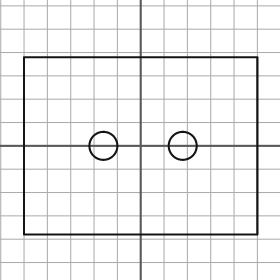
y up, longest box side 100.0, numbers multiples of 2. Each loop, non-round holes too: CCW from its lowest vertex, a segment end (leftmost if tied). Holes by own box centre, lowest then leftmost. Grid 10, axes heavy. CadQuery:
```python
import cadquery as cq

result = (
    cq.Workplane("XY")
    .moveTo(-50.0, -38.0)
    .lineTo(50.0, -38.0)
    .lineTo(50.0, 38.0)
    .lineTo(-50.0, 38.0)
    .close()
    .moveTo(-16.0, 0.0)
    .circle(6.0)
    .moveTo(18.0, 0.0)
    .circle(6.0)
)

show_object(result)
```